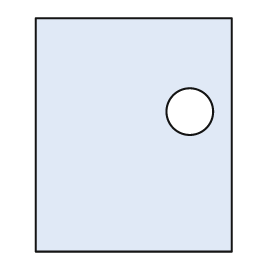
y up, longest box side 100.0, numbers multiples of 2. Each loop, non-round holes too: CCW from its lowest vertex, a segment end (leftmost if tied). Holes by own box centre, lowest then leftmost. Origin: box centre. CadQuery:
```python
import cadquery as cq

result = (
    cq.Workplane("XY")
    .moveTo(-42.0, -50.0)
    .lineTo(42.0, -50.0)
    .lineTo(42.0, 50.0)
    .lineTo(-42.0, 50.0)
    .close()
    .moveTo(24.0, 10.0)
    .circle(10.0)
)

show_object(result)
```